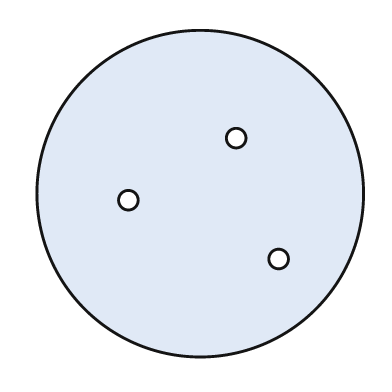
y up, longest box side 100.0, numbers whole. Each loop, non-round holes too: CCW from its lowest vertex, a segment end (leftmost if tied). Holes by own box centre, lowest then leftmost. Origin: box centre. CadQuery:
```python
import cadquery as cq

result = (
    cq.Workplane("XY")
    .moveTo(0.0, 0.0)
    .circle(50.0)
    .moveTo(24.0, -20.0)
    .circle(3.0)
    .moveTo(-22.0, -2.0)
    .circle(3.0)
    .moveTo(11.0, 17.0)
    .circle(3.0)
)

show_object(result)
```